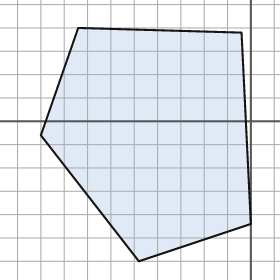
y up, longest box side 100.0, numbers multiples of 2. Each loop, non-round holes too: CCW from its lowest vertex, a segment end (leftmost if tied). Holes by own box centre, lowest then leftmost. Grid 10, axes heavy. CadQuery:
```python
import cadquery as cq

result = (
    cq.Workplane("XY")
    .moveTo(-48.0, -60.0)
    .lineTo(0.0, -44.0)
    .lineTo(-4.0, 38.0)
    .lineTo(-74.0, 40.0)
    .lineTo(-90.0, -6.0)
    .close()
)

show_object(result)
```